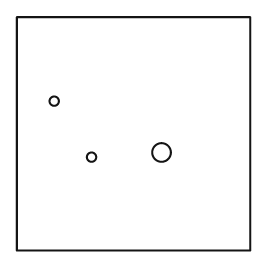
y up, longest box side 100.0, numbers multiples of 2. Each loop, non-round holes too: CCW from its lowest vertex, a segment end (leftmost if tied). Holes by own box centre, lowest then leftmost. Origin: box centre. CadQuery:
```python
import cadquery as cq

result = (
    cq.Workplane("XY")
    .moveTo(-50.0, -50.0)
    .lineTo(50.0, -50.0)
    .lineTo(50.0, 50.0)
    .lineTo(-50.0, 50.0)
    .close()
    .moveTo(-18.0, -10.0)
    .circle(2.0)
    .moveTo(12.0, -8.0)
    .circle(4.0)
    .moveTo(-34.0, 14.0)
    .circle(2.0)
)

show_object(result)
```